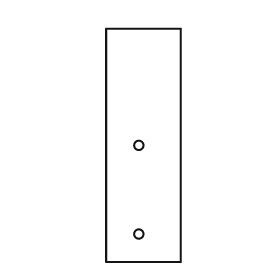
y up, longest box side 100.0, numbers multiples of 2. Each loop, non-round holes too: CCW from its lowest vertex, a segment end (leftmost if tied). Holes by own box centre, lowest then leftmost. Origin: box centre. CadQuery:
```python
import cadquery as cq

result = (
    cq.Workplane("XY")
    .moveTo(-16.0, -50.0)
    .lineTo(16.0, -50.0)
    .lineTo(16.0, 50.0)
    .lineTo(-16.0, 50.0)
    .close()
    .moveTo(-2.0, -38.0)
    .circle(2.0)
    .moveTo(-2.0, 0.0)
    .circle(2.0)
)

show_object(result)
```